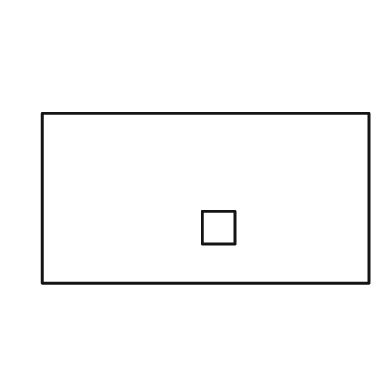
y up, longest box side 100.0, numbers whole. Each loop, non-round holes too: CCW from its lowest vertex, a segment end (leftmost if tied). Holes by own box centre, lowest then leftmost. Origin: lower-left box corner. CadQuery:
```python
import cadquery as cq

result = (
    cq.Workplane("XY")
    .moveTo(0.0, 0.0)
    .lineTo(100.0, 0.0)
    .lineTo(100.0, 52.0)
    .lineTo(0.0, 52.0)
    .close()
    .moveTo(49.0, 12.0)
    .lineTo(59.0, 12.0)
    .lineTo(59.0, 22.0)
    .lineTo(49.0, 22.0)
    .close()
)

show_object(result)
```